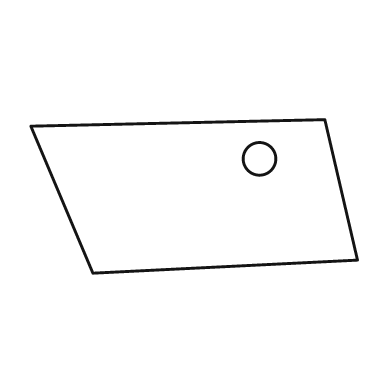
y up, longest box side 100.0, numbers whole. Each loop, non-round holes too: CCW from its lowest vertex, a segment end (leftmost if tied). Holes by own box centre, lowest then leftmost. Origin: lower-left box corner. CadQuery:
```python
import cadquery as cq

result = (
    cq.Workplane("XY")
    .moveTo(19.0, 0.0)
    .lineTo(100.0, 4.0)
    .lineTo(90.0, 47.0)
    .lineTo(0.0, 45.0)
    .close()
    .moveTo(70.0, 35.0)
    .circle(5.0)
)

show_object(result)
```